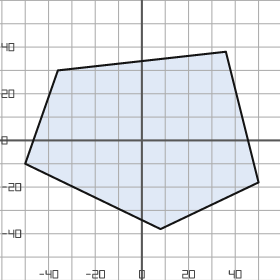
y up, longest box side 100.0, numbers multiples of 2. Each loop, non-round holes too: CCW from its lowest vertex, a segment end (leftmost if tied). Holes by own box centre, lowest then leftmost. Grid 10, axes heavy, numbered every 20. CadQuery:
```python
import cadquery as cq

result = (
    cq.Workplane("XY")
    .moveTo(8.0, -38.0)
    .lineTo(50.0, -18.0)
    .lineTo(36.0, 38.0)
    .lineTo(-36.0, 30.0)
    .lineTo(-50.0, -10.0)
    .close()
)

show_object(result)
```